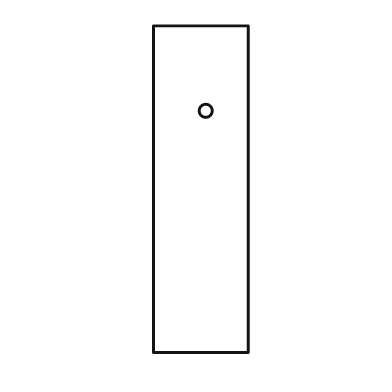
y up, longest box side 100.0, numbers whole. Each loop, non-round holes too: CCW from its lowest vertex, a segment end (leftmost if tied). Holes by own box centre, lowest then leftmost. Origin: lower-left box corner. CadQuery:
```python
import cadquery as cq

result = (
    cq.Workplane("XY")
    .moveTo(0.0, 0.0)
    .lineTo(29.0, 0.0)
    .lineTo(29.0, 100.0)
    .lineTo(0.0, 100.0)
    .close()
    .moveTo(16.0, 74.0)
    .circle(2.0)
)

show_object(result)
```